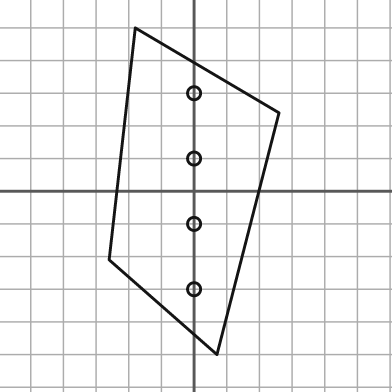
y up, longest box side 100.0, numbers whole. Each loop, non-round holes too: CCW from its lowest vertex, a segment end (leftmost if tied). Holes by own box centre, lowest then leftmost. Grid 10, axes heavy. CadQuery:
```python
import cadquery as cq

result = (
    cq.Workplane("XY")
    .moveTo(7.0, -50.0)
    .lineTo(26.0, 24.0)
    .lineTo(-18.0, 50.0)
    .lineTo(-26.0, -21.0)
    .close()
    .moveTo(0.0, -30.0)
    .circle(2.0)
    .moveTo(0.0, -10.0)
    .circle(2.0)
    .moveTo(0.0, 10.0)
    .circle(2.0)
    .moveTo(0.0, 30.0)
    .circle(2.0)
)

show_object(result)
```